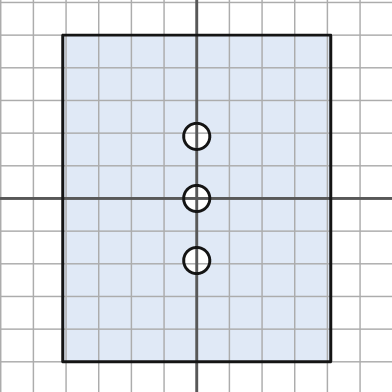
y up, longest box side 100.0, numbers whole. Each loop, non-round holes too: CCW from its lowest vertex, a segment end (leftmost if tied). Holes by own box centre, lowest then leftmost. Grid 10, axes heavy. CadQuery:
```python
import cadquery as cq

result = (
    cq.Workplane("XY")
    .moveTo(-41.0, -50.0)
    .lineTo(41.0, -50.0)
    .lineTo(41.0, 50.0)
    .lineTo(-41.0, 50.0)
    .close()
    .moveTo(0.0, -19.0)
    .circle(4.0)
    .moveTo(0.0, 0.0)
    .circle(4.0)
    .moveTo(0.0, 19.0)
    .circle(4.0)
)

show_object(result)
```